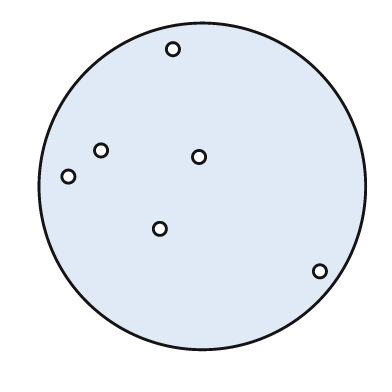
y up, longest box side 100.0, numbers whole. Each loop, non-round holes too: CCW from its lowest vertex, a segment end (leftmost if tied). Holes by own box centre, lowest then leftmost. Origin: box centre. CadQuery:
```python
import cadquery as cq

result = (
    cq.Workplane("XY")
    .moveTo(0.0, 0.0)
    .circle(50.0)
    .moveTo(36.0, -26.0)
    .circle(2.0)
    .moveTo(-13.0, -13.0)
    .circle(2.0)
    .moveTo(-41.0, 3.0)
    .circle(2.0)
    .moveTo(-1.0, 9.0)
    .circle(2.0)
    .moveTo(-31.0, 11.0)
    .circle(2.0)
    .moveTo(-9.0, 42.0)
    .circle(2.0)
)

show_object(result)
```